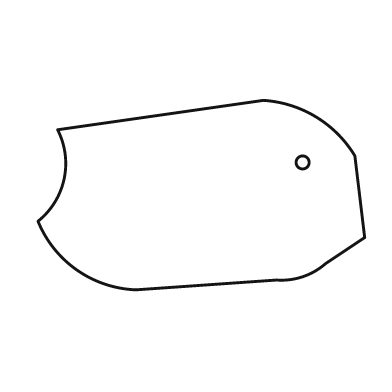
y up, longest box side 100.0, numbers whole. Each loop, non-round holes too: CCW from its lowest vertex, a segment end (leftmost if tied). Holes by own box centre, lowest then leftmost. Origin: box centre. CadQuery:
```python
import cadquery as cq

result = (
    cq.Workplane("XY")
    .moveTo(-20.0, -29.0)
    .lineTo(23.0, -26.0)
    .threePointArc((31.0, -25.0), (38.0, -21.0))
    .lineTo(50.0, -13.0)
    .lineTo(47.0, 12.0)
    .threePointArc((35.0, 24.0), (19.0, 29.0))
    .lineTo(-44.0, 20.0)
    .threePointArc((-42.0, 5.0), (-50.0, -8.0))
    .threePointArc((-38.0, -23.0), (-20.0, -29.0))
    .close()
    .moveTo(31.0, 10.0)
    .circle(2.0)
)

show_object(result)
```